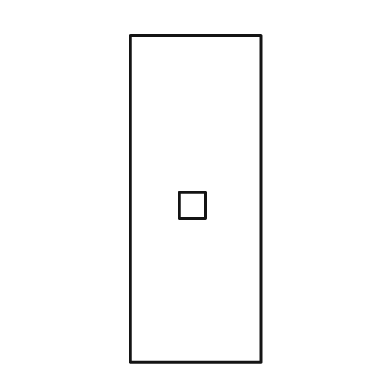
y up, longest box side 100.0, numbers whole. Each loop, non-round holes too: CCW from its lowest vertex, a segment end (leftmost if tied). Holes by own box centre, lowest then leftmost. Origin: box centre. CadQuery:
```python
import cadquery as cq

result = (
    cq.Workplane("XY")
    .moveTo(-20.0, -50.0)
    .lineTo(20.0, -50.0)
    .lineTo(20.0, 50.0)
    .lineTo(-20.0, 50.0)
    .close()
    .moveTo(-5.0, -6.0)
    .lineTo(3.0, -6.0)
    .lineTo(3.0, 2.0)
    .lineTo(-5.0, 2.0)
    .close()
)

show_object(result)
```